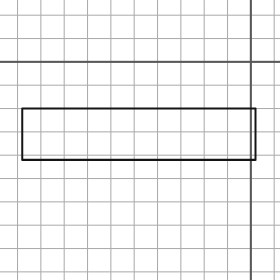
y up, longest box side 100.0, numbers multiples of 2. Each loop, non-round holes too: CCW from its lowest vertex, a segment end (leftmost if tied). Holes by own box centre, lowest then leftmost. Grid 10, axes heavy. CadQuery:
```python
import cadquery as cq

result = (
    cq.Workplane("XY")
    .moveTo(-98.0, -42.0)
    .lineTo(2.0, -42.0)
    .lineTo(2.0, -20.0)
    .lineTo(-98.0, -20.0)
    .close()
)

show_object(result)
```